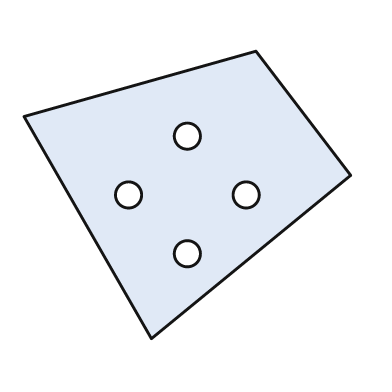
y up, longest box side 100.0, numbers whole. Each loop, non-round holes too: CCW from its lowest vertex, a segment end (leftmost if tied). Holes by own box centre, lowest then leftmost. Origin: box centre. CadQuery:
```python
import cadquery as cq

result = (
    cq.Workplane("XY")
    .moveTo(-11.0, -44.0)
    .lineTo(50.0, 6.0)
    .lineTo(21.0, 44.0)
    .lineTo(-50.0, 24.0)
    .close()
    .moveTo(0.0, -18.0)
    .circle(4.0)
    .moveTo(-18.0, 0.0)
    .circle(4.0)
    .moveTo(18.0, 0.0)
    .circle(4.0)
    .moveTo(0.0, 18.0)
    .circle(4.0)
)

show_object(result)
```